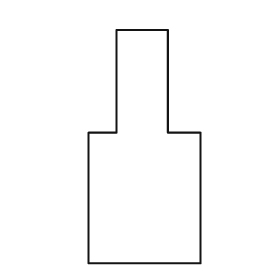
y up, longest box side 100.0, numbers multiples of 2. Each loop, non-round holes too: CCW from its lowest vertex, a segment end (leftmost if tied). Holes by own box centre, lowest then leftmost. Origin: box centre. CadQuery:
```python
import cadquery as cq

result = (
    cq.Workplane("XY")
    .moveTo(-24.0, -50.0)
    .lineTo(24.0, -50.0)
    .lineTo(24.0, 6.0)
    .lineTo(10.0, 6.0)
    .lineTo(10.0, 50.0)
    .lineTo(-12.0, 50.0)
    .lineTo(-12.0, 6.0)
    .lineTo(-24.0, 6.0)
    .close()
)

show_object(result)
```